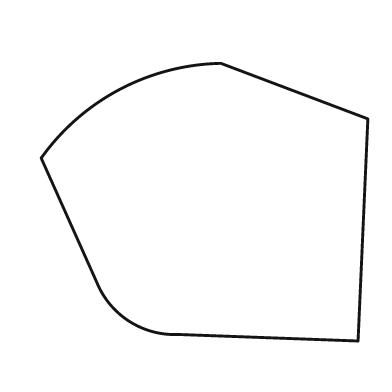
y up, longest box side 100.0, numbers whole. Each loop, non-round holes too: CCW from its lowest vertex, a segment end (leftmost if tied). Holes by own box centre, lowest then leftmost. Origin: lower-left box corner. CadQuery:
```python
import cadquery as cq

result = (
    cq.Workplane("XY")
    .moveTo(97.0, 0.0)
    .lineTo(100.0, 68.0)
    .lineTo(55.0, 85.0)
    .threePointArc((24.0, 77.0), (0.0, 56.0))
    .lineTo(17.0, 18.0)
    .threePointArc((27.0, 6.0), (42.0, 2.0))
    .close()
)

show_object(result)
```